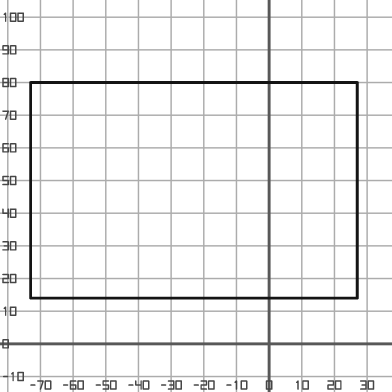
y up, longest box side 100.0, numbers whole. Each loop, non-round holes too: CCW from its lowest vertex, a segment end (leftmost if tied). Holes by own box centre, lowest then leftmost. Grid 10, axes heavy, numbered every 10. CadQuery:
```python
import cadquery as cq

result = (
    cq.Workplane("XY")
    .moveTo(-73.0, 14.0)
    .lineTo(27.0, 14.0)
    .lineTo(27.0, 80.0)
    .lineTo(-73.0, 80.0)
    .close()
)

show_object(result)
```